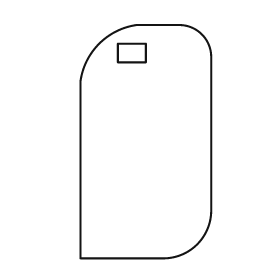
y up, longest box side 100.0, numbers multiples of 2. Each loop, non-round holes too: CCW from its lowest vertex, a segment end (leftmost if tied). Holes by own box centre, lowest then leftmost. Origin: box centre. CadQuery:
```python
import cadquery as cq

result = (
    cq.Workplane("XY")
    .moveTo(-28.0, -50.0)
    .lineTo(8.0, -50.0)
    .threePointArc((22.0, -44.0), (28.0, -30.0))
    .lineTo(28.0, 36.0)
    .threePointArc((24.0, 46.0), (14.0, 50.0))
    .lineTo(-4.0, 50.0)
    .threePointArc((-20.0, 42.0), (-28.0, 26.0))
    .close()
    .moveTo(-12.0, 34.0)
    .lineTo(0.0, 34.0)
    .lineTo(0.0, 42.0)
    .lineTo(-12.0, 42.0)
    .close()
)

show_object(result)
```